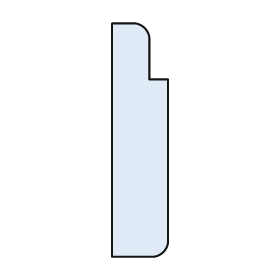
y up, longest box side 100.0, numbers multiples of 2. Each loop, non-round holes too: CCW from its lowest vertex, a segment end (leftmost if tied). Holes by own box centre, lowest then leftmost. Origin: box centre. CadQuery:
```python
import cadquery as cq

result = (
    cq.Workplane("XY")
    .moveTo(-12.0, -50.0)
    .lineTo(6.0, -50.0)
    .threePointArc((10.0, -48.0), (12.0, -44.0))
    .lineTo(12.0, 26.0)
    .lineTo(4.0, 26.0)
    .lineTo(4.0, 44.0)
    .threePointArc((2.0, 48.0), (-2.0, 50.0))
    .lineTo(-12.0, 50.0)
    .close()
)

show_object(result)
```